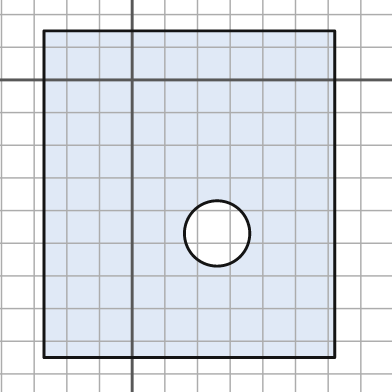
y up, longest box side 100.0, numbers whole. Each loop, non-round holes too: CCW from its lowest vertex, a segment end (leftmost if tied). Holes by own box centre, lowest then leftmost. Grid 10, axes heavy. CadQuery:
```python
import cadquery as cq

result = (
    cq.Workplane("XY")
    .moveTo(-27.0, -85.0)
    .lineTo(62.0, -85.0)
    .lineTo(62.0, 15.0)
    .lineTo(-27.0, 15.0)
    .close()
    .moveTo(26.0, -47.0)
    .circle(10.0)
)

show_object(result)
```